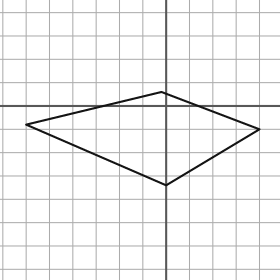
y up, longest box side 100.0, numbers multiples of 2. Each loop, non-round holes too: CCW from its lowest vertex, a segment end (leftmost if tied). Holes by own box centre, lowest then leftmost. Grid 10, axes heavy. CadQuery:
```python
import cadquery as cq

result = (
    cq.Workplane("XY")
    .moveTo(0.0, -34.0)
    .lineTo(40.0, -10.0)
    .lineTo(-2.0, 6.0)
    .lineTo(-60.0, -8.0)
    .close()
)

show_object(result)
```